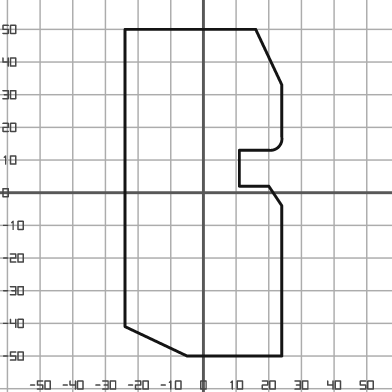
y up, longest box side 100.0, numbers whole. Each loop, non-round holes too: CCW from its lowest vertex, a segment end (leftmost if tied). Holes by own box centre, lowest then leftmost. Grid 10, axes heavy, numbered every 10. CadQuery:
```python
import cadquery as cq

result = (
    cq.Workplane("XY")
    .moveTo(-5.0, -50.0)
    .lineTo(24.0, -50.0)
    .lineTo(24.0, -4.0)
    .lineTo(20.0, 2.0)
    .lineTo(11.0, 2.0)
    .lineTo(11.0, 13.0)
    .lineTo(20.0, 13.0)
    .threePointArc((23.0, 14.0), (24.0, 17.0))
    .lineTo(24.0, 33.0)
    .lineTo(16.0, 50.0)
    .lineTo(-24.0, 50.0)
    .lineTo(-24.0, -41.0)
    .close()
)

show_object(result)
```